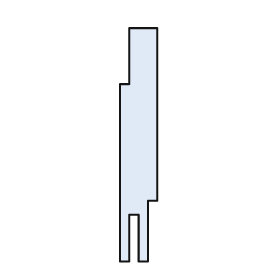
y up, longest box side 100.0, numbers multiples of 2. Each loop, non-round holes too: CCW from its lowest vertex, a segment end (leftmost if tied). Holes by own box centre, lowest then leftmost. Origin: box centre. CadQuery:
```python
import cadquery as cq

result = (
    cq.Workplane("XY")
    .moveTo(-8.0, -50.0)
    .lineTo(-4.0, -50.0)
    .lineTo(-4.0, -30.0)
    .lineTo(0.0, -30.0)
    .lineTo(0.0, -50.0)
    .lineTo(4.0, -50.0)
    .lineTo(4.0, -24.0)
    .lineTo(8.0, -24.0)
    .lineTo(8.0, 50.0)
    .lineTo(-4.0, 50.0)
    .lineTo(-4.0, 26.0)
    .lineTo(-8.0, 26.0)
    .close()
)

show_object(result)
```